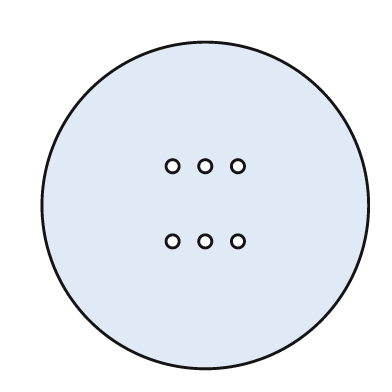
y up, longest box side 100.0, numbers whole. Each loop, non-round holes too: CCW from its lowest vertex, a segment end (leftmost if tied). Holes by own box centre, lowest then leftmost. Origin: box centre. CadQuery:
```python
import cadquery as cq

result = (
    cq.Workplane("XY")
    .moveTo(0.0, 0.0)
    .circle(50.0)
    .moveTo(-10.0, -11.0)
    .circle(2.0)
    .moveTo(0.0, -11.0)
    .circle(2.0)
    .moveTo(10.0, -11.0)
    .circle(2.0)
    .moveTo(-10.0, 12.0)
    .circle(2.0)
    .moveTo(0.0, 12.0)
    .circle(2.0)
    .moveTo(10.0, 12.0)
    .circle(2.0)
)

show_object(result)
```